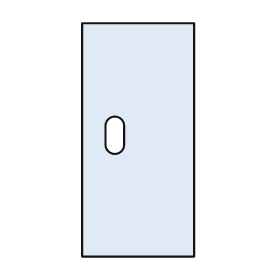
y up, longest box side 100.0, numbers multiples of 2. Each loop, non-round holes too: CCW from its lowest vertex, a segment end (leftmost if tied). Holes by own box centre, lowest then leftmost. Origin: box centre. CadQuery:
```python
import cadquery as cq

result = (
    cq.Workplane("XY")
    .moveTo(-24.0, -50.0)
    .lineTo(24.0, -50.0)
    .lineTo(24.0, 50.0)
    .lineTo(-24.0, 50.0)
    .close()
    .moveTo(-14.0, -2.0)
    .threePointArc((-10.0, -6.0), (-6.0, -2.0))
    .lineTo(-6.0, 6.0)
    .threePointArc((-10.0, 10.0), (-14.0, 6.0))
    .close()
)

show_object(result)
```